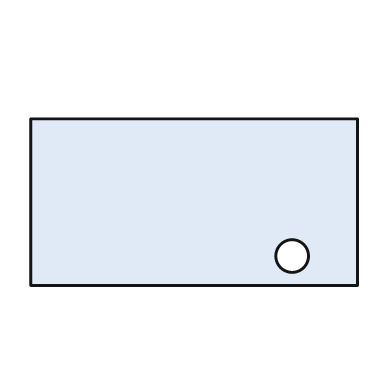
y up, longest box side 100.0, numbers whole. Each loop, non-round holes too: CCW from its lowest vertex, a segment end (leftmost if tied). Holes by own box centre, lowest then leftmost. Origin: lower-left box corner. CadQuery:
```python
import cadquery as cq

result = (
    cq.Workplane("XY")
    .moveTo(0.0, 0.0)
    .lineTo(100.0, 0.0)
    .lineTo(100.0, 51.0)
    .lineTo(0.0, 51.0)
    .close()
    .moveTo(80.0, 9.0)
    .circle(5.0)
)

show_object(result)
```